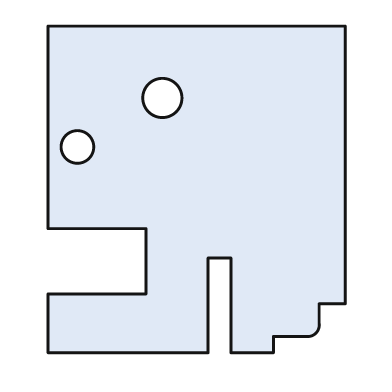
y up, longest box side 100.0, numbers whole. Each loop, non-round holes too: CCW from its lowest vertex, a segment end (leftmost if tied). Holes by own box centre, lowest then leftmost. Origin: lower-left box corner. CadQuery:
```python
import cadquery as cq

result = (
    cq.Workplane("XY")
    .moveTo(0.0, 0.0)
    .lineTo(49.0, 0.0)
    .lineTo(49.0, 29.0)
    .lineTo(56.0, 29.0)
    .lineTo(56.0, 0.0)
    .lineTo(69.0, 0.0)
    .lineTo(69.0, 5.0)
    .lineTo(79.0, 5.0)
    .threePointArc((82.0, 6.0), (83.0, 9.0))
    .lineTo(83.0, 15.0)
    .lineTo(91.0, 15.0)
    .lineTo(91.0, 100.0)
    .lineTo(0.0, 100.0)
    .lineTo(0.0, 38.0)
    .lineTo(30.0, 38.0)
    .lineTo(30.0, 18.0)
    .lineTo(0.0, 18.0)
    .close()
    .moveTo(9.0, 63.0)
    .circle(5.0)
    .moveTo(35.0, 78.0)
    .circle(6.0)
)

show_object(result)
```